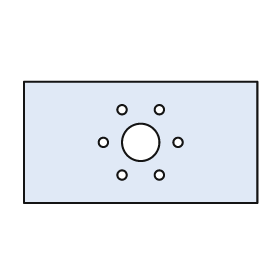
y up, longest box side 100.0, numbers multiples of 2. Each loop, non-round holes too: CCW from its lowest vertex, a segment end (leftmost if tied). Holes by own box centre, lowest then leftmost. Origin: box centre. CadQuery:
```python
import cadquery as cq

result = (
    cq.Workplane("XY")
    .moveTo(-50.0, -26.0)
    .lineTo(50.0, -26.0)
    .lineTo(50.0, 26.0)
    .lineTo(-50.0, 26.0)
    .close()
    .moveTo(-8.0, -14.0)
    .circle(2.0)
    .moveTo(8.0, -14.0)
    .circle(2.0)
    .moveTo(-16.0, 0.0)
    .circle(2.0)
    .moveTo(0.0, 0.0)
    .circle(8.0)
    .moveTo(16.0, 0.0)
    .circle(2.0)
    .moveTo(-8.0, 14.0)
    .circle(2.0)
    .moveTo(8.0, 14.0)
    .circle(2.0)
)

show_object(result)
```